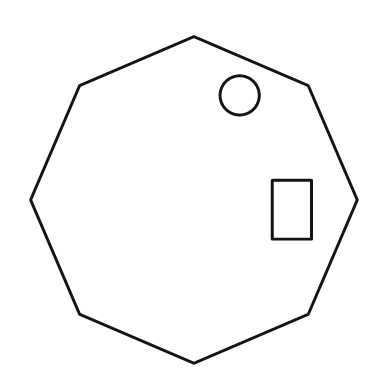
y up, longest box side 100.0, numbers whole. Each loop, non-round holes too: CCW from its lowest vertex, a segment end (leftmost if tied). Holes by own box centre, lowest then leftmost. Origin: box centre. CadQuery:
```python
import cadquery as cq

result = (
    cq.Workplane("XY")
    .moveTo(0.0, -50.0)
    .lineTo(35.0, -35.0)
    .lineTo(50.0, 0.0)
    .lineTo(35.0, 35.0)
    .lineTo(0.0, 50.0)
    .lineTo(-35.0, 35.0)
    .lineTo(-50.0, 0.0)
    .lineTo(-35.0, -35.0)
    .close()
    .moveTo(24.0, -12.0)
    .lineTo(36.0, -12.0)
    .lineTo(36.0, 6.0)
    .lineTo(24.0, 6.0)
    .close()
    .moveTo(14.0, 32.0)
    .circle(6.0)
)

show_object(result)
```